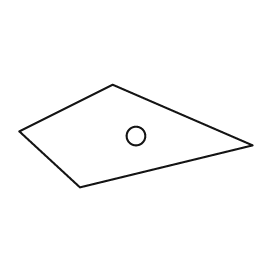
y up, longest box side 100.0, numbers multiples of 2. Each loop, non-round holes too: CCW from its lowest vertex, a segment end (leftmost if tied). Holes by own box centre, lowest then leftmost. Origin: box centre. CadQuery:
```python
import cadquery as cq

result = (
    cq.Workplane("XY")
    .moveTo(-24.0, -22.0)
    .lineTo(50.0, -4.0)
    .lineTo(-10.0, 22.0)
    .lineTo(-50.0, 2.0)
    .close()
    .moveTo(0.0, 0.0)
    .circle(4.0)
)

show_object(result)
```